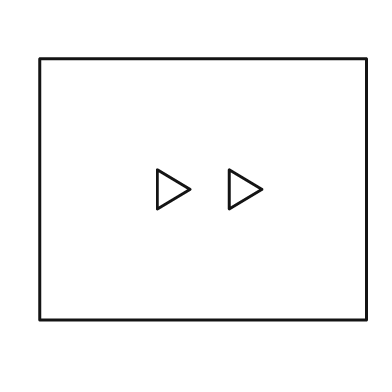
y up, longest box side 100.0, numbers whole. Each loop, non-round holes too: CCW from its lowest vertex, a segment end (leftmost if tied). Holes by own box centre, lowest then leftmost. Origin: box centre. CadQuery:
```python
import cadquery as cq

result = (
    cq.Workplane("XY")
    .moveTo(-50.0, -40.0)
    .lineTo(50.0, -40.0)
    .lineTo(50.0, 40.0)
    .lineTo(-50.0, 40.0)
    .close()
    .moveTo(-14.0, -6.0)
    .lineTo(-4.0, 0.0)
    .lineTo(-14.0, 6.0)
    .close()
    .moveTo(8.0, -6.0)
    .lineTo(18.0, 0.0)
    .lineTo(8.0, 6.0)
    .close()
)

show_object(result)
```